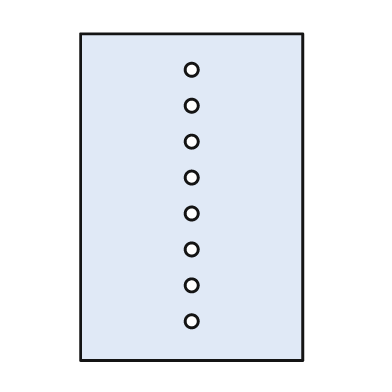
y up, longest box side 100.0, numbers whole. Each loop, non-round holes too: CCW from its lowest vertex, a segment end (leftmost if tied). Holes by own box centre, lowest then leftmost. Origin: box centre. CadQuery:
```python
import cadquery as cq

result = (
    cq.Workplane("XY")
    .moveTo(-34.0, -50.0)
    .lineTo(34.0, -50.0)
    .lineTo(34.0, 50.0)
    .lineTo(-34.0, 50.0)
    .close()
    .moveTo(0.0, -38.0)
    .circle(2.0)
    .moveTo(0.0, -27.0)
    .circle(2.0)
    .moveTo(0.0, -16.0)
    .circle(2.0)
    .moveTo(0.0, -5.0)
    .circle(2.0)
    .moveTo(0.0, 6.0)
    .circle(2.0)
    .moveTo(0.0, 17.0)
    .circle(2.0)
    .moveTo(0.0, 28.0)
    .circle(2.0)
    .moveTo(0.0, 39.0)
    .circle(2.0)
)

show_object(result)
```